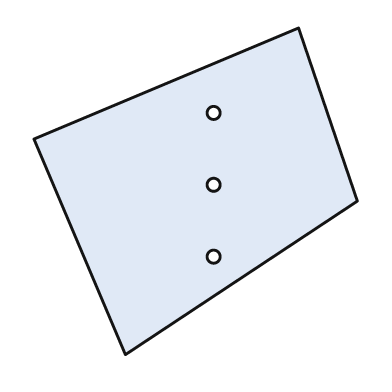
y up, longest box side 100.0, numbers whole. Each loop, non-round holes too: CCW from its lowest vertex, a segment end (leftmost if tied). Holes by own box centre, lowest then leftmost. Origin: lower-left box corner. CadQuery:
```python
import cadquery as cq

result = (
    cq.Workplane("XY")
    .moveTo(28.0, 0.0)
    .lineTo(99.0, 47.0)
    .lineTo(81.0, 100.0)
    .lineTo(0.0, 66.0)
    .close()
    .moveTo(55.0, 30.0)
    .circle(2.0)
    .moveTo(55.0, 52.0)
    .circle(2.0)
    .moveTo(55.0, 74.0)
    .circle(2.0)
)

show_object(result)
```